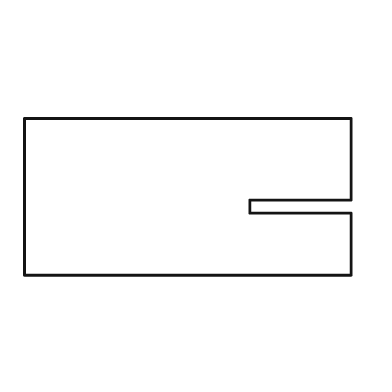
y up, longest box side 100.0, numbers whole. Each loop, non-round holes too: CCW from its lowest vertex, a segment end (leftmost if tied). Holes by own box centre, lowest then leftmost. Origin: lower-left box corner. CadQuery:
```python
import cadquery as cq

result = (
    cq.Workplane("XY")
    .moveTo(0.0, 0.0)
    .lineTo(100.0, 0.0)
    .lineTo(100.0, 19.0)
    .lineTo(69.0, 19.0)
    .lineTo(69.0, 23.0)
    .lineTo(100.0, 23.0)
    .lineTo(100.0, 48.0)
    .lineTo(0.0, 48.0)
    .close()
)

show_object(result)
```